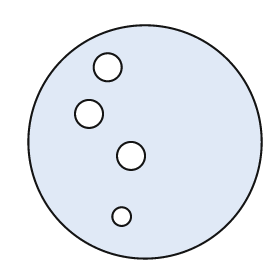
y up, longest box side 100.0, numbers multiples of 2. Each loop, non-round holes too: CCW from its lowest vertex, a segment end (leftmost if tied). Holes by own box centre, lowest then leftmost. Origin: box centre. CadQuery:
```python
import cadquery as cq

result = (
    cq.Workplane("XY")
    .moveTo(0.0, 0.0)
    .circle(50.0)
    .moveTo(-10.0, -32.0)
    .circle(4.0)
    .moveTo(-6.0, -6.0)
    .circle(6.0)
    .moveTo(-24.0, 12.0)
    .circle(6.0)
    .moveTo(-16.0, 32.0)
    .circle(6.0)
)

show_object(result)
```